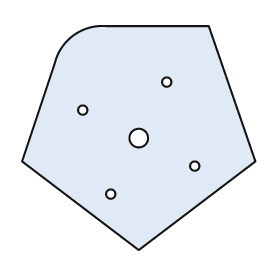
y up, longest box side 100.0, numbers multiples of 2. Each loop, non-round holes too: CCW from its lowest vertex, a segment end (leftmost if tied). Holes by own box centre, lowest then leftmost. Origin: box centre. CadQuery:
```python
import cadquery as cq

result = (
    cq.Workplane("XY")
    .moveTo(0.0, -48.0)
    .lineTo(50.0, -10.0)
    .lineTo(30.0, 48.0)
    .lineTo(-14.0, 48.0)
    .threePointArc((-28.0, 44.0), (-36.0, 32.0))
    .lineTo(-50.0, -10.0)
    .close()
    .moveTo(-12.0, -24.0)
    .circle(2.0)
    .moveTo(24.0, -12.0)
    .circle(2.0)
    .moveTo(0.0, 0.0)
    .circle(4.0)
    .moveTo(-24.0, 12.0)
    .circle(2.0)
    .moveTo(12.0, 24.0)
    .circle(2.0)
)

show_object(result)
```